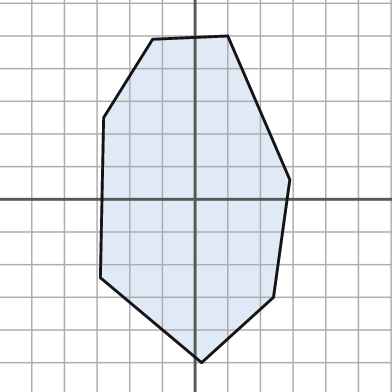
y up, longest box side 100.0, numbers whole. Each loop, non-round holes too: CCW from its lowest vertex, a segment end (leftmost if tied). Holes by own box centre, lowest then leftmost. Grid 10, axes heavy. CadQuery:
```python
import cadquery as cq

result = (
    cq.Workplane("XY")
    .moveTo(2.0, -50.0)
    .lineTo(24.0, -30.0)
    .lineTo(29.0, 6.0)
    .lineTo(10.0, 50.0)
    .lineTo(-13.0, 49.0)
    .lineTo(-28.0, 25.0)
    .lineTo(-29.0, -24.0)
    .close()
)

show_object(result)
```